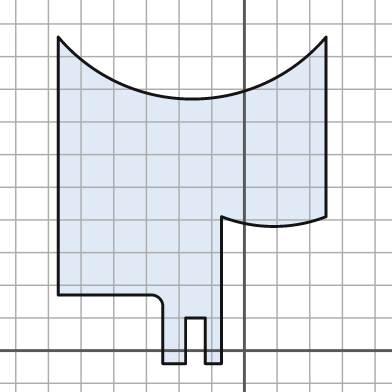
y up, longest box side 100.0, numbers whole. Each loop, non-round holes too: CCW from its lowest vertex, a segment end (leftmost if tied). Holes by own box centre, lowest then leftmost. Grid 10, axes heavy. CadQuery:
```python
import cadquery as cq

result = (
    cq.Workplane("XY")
    .moveTo(-25.0, -4.0)
    .lineTo(-18.0, -4.0)
    .lineTo(-18.0, 10.0)
    .lineTo(-12.0, 10.0)
    .lineTo(-12.0, -4.0)
    .lineTo(-7.0, -4.0)
    .lineTo(-7.0, 41.0)
    .threePointArc((9.0, 38.0), (25.0, 41.0))
    .lineTo(25.0, 96.0)
    .threePointArc((-16.0, 77.0), (-57.0, 96.0))
    .lineTo(-57.0, 17.0)
    .lineTo(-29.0, 17.0)
    .threePointArc((-26.0, 16.0), (-25.0, 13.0))
    .close()
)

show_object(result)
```